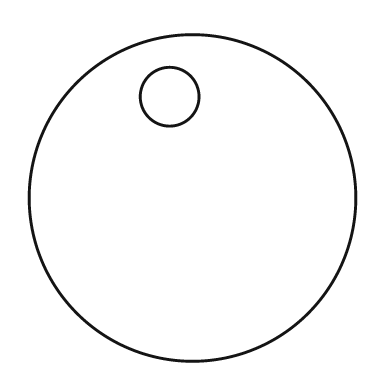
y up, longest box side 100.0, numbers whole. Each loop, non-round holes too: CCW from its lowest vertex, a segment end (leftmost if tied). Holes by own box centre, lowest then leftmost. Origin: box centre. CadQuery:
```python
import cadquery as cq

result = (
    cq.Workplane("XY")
    .moveTo(0.0, 0.0)
    .circle(50.0)
    .moveTo(-7.0, 31.0)
    .circle(9.0)
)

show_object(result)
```